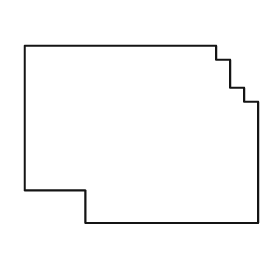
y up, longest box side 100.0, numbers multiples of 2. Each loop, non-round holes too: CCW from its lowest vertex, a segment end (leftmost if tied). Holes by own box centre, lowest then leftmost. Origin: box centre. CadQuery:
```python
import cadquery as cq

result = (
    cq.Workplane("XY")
    .moveTo(-24.0, -38.0)
    .lineTo(50.0, -38.0)
    .lineTo(50.0, 14.0)
    .lineTo(44.0, 14.0)
    .lineTo(44.0, 20.0)
    .lineTo(38.0, 20.0)
    .lineTo(38.0, 32.0)
    .lineTo(32.0, 32.0)
    .lineTo(32.0, 38.0)
    .lineTo(-50.0, 38.0)
    .lineTo(-50.0, -24.0)
    .lineTo(-24.0, -24.0)
    .close()
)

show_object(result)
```